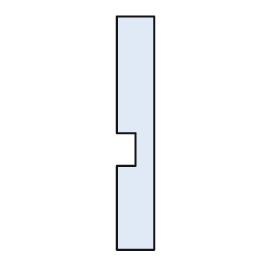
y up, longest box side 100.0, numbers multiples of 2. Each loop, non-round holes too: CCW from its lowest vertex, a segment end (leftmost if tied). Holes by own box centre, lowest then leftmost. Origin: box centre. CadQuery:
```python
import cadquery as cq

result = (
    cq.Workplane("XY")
    .moveTo(-8.0, -50.0)
    .lineTo(8.0, -50.0)
    .lineTo(8.0, 50.0)
    .lineTo(-8.0, 50.0)
    .lineTo(-8.0, 0.0)
    .lineTo(0.0, 0.0)
    .lineTo(0.0, -14.0)
    .lineTo(-8.0, -14.0)
    .close()
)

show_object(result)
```